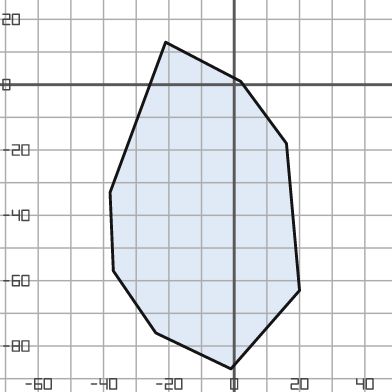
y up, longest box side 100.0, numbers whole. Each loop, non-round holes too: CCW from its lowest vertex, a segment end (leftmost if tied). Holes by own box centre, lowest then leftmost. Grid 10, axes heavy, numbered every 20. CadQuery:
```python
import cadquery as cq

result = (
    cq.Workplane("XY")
    .moveTo(-1.0, -87.0)
    .lineTo(20.0, -63.0)
    .lineTo(16.0, -18.0)
    .lineTo(2.0, 1.0)
    .lineTo(-21.0, 13.0)
    .lineTo(-38.0, -33.0)
    .lineTo(-37.0, -57.0)
    .lineTo(-24.0, -76.0)
    .close()
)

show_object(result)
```